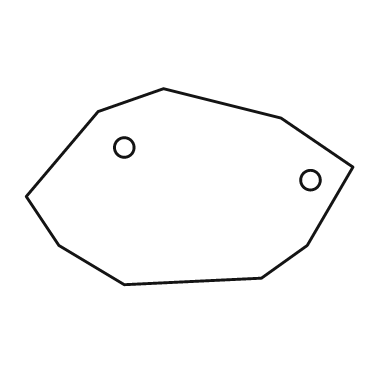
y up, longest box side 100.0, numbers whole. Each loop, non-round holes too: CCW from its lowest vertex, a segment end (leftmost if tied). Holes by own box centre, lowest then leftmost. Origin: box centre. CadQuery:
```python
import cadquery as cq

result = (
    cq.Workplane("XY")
    .moveTo(-20.0, -30.0)
    .lineTo(22.0, -28.0)
    .lineTo(36.0, -18.0)
    .lineTo(50.0, 6.0)
    .lineTo(28.0, 21.0)
    .lineTo(-8.0, 30.0)
    .lineTo(-28.0, 23.0)
    .lineTo(-50.0, -3.0)
    .lineTo(-40.0, -18.0)
    .close()
    .moveTo(37.0, 2.0)
    .circle(3.0)
    .moveTo(-20.0, 12.0)
    .circle(3.0)
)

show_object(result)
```